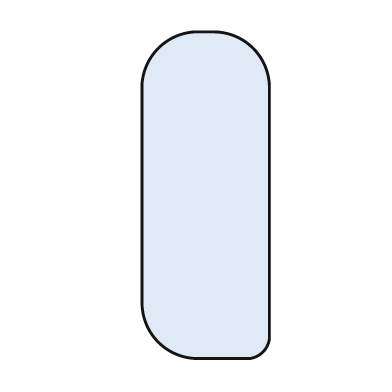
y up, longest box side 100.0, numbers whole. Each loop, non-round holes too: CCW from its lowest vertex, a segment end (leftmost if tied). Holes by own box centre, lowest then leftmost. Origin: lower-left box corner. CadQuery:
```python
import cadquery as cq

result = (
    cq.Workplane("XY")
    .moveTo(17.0, 0.0)
    .lineTo(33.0, 0.0)
    .threePointArc((37.0, 2.0), (39.0, 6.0))
    .lineTo(39.0, 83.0)
    .threePointArc((34.0, 95.0), (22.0, 100.0))
    .lineTo(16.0, 100.0)
    .threePointArc((5.0, 95.0), (0.0, 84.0))
    .lineTo(0.0, 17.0)
    .threePointArc((5.0, 5.0), (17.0, 0.0))
    .close()
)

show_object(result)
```